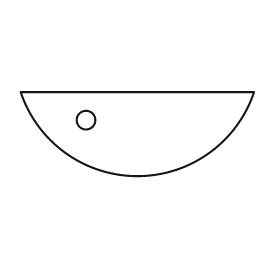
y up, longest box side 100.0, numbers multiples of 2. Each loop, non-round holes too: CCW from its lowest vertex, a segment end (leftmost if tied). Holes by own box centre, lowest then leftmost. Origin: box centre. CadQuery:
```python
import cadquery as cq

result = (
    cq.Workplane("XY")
    .moveTo(-50.0, 18.0)
    .threePointArc((0.0, -18.0), (50.0, 18.0))
    .close()
    .moveTo(-22.0, 6.0)
    .circle(4.0)
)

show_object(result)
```